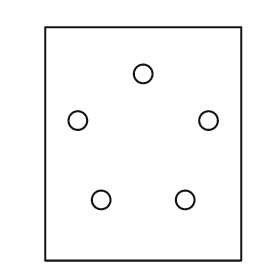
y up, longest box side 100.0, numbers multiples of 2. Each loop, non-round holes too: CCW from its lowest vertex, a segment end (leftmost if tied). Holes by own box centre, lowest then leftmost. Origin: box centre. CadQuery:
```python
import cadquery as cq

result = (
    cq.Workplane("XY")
    .moveTo(-42.0, -50.0)
    .lineTo(42.0, -50.0)
    .lineTo(42.0, 50.0)
    .lineTo(-42.0, 50.0)
    .close()
    .moveTo(-18.0, -24.0)
    .circle(4.0)
    .moveTo(18.0, -24.0)
    .circle(4.0)
    .moveTo(-28.0, 10.0)
    .circle(4.0)
    .moveTo(28.0, 10.0)
    .circle(4.0)
    .moveTo(0.0, 30.0)
    .circle(4.0)
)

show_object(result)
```